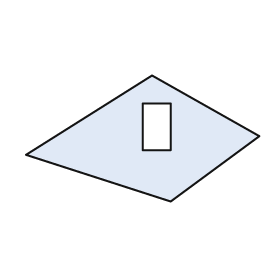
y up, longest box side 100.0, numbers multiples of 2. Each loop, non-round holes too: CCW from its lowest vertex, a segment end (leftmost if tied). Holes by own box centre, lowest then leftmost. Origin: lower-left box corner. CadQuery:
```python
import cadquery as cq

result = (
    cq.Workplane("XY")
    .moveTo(62.0, 0.0)
    .lineTo(100.0, 28.0)
    .lineTo(54.0, 54.0)
    .lineTo(0.0, 20.0)
    .close()
    .moveTo(50.0, 22.0)
    .lineTo(62.0, 22.0)
    .lineTo(62.0, 42.0)
    .lineTo(50.0, 42.0)
    .close()
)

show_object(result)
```